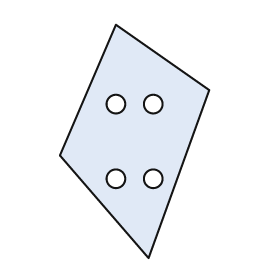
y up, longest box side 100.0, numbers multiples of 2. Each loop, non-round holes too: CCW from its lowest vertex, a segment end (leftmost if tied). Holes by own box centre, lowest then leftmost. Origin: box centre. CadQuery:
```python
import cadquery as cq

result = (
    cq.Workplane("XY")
    .moveTo(6.0, -50.0)
    .lineTo(32.0, 22.0)
    .lineTo(-8.0, 50.0)
    .lineTo(-32.0, -6.0)
    .close()
    .moveTo(-8.0, -16.0)
    .circle(4.0)
    .moveTo(8.0, -16.0)
    .circle(4.0)
    .moveTo(-8.0, 16.0)
    .circle(4.0)
    .moveTo(8.0, 16.0)
    .circle(4.0)
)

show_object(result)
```